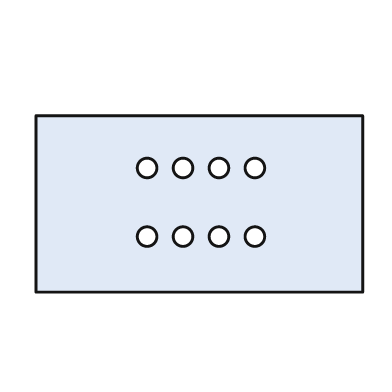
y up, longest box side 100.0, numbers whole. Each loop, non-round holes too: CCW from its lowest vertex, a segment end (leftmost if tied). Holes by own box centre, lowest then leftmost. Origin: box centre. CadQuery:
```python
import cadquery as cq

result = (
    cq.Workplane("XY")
    .moveTo(-50.0, -27.0)
    .lineTo(50.0, -27.0)
    .lineTo(50.0, 27.0)
    .lineTo(-50.0, 27.0)
    .close()
    .moveTo(-16.0, -10.0)
    .circle(3.0)
    .moveTo(-5.0, -10.0)
    .circle(3.0)
    .moveTo(6.0, -10.0)
    .circle(3.0)
    .moveTo(17.0, -10.0)
    .circle(3.0)
    .moveTo(-16.0, 11.0)
    .circle(3.0)
    .moveTo(-5.0, 11.0)
    .circle(3.0)
    .moveTo(6.0, 11.0)
    .circle(3.0)
    .moveTo(17.0, 11.0)
    .circle(3.0)
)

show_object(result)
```